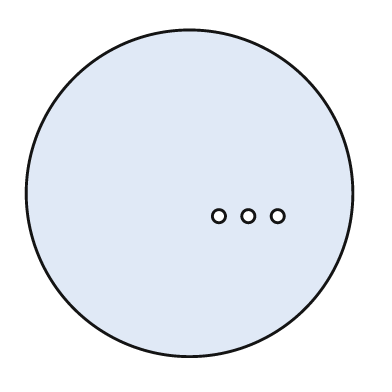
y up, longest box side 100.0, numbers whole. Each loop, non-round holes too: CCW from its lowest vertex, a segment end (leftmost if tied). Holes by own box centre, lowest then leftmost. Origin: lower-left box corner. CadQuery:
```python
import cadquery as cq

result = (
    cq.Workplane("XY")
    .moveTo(50.0, 50.0)
    .circle(50.0)
    .moveTo(59.0, 43.0)
    .circle(2.0)
    .moveTo(68.0, 43.0)
    .circle(2.0)
    .moveTo(77.0, 43.0)
    .circle(2.0)
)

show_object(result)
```